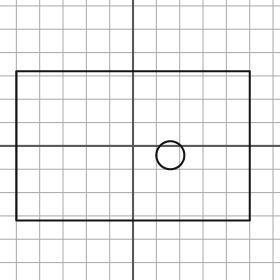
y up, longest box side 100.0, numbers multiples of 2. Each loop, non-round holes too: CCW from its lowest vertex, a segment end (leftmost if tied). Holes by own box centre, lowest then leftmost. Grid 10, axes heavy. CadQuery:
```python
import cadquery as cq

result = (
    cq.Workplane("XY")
    .moveTo(-50.0, -32.0)
    .lineTo(50.0, -32.0)
    .lineTo(50.0, 32.0)
    .lineTo(-50.0, 32.0)
    .close()
    .moveTo(16.0, -4.0)
    .circle(6.0)
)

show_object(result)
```